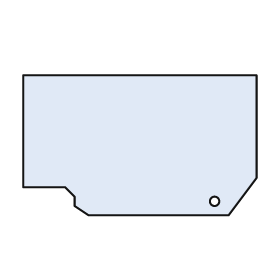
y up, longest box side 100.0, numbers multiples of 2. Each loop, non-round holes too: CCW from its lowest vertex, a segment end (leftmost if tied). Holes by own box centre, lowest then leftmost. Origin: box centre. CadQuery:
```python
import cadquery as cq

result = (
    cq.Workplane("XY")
    .moveTo(-22.0, -30.0)
    .lineTo(38.0, -30.0)
    .lineTo(50.0, -14.0)
    .lineTo(50.0, 30.0)
    .lineTo(-50.0, 30.0)
    .lineTo(-50.0, -18.0)
    .lineTo(-32.0, -18.0)
    .lineTo(-28.0, -22.0)
    .lineTo(-28.0, -26.0)
    .close()
    .moveTo(32.0, -24.0)
    .circle(2.0)
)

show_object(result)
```